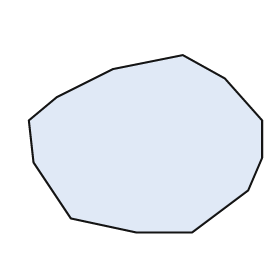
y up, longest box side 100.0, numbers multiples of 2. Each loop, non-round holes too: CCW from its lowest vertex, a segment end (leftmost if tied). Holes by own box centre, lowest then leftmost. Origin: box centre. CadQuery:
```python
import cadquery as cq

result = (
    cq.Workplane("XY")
    .moveTo(-4.0, -38.0)
    .lineTo(20.0, -38.0)
    .lineTo(44.0, -20.0)
    .lineTo(50.0, -6.0)
    .lineTo(50.0, 10.0)
    .lineTo(34.0, 28.0)
    .lineTo(16.0, 38.0)
    .lineTo(-14.0, 32.0)
    .lineTo(-38.0, 20.0)
    .lineTo(-50.0, 10.0)
    .lineTo(-48.0, -8.0)
    .lineTo(-32.0, -32.0)
    .close()
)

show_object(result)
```